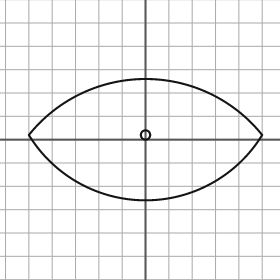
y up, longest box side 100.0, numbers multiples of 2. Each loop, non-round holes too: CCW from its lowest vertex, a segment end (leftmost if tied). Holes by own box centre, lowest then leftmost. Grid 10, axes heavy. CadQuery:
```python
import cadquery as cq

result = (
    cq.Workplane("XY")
    .moveTo(-50.0, 2.0)
    .threePointArc((0.0, -26.0), (50.0, 2.0))
    .threePointArc((0.0, 26.0), (-50.0, 2.0))
    .close()
    .moveTo(0.0, 2.0)
    .circle(2.0)
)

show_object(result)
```